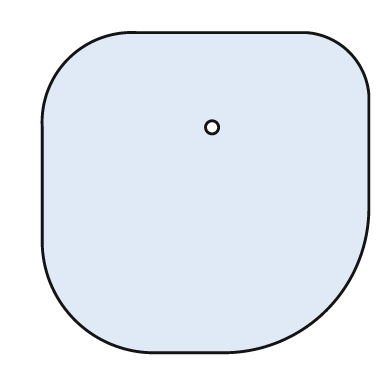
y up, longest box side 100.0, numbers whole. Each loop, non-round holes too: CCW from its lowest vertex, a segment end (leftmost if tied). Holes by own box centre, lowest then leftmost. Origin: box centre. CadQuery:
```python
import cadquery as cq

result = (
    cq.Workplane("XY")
    .moveTo(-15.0, -49.0)
    .lineTo(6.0, -49.0)
    .threePointArc((37.0, -36.0), (50.0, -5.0))
    .lineTo(50.0, 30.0)
    .threePointArc((44.0, 43.0), (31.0, 49.0))
    .lineTo(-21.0, 49.0)
    .threePointArc((-42.0, 41.0), (-50.0, 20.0))
    .lineTo(-50.0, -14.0)
    .threePointArc((-40.0, -39.0), (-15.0, -49.0))
    .close()
    .moveTo(2.0, 20.0)
    .circle(2.0)
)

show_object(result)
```